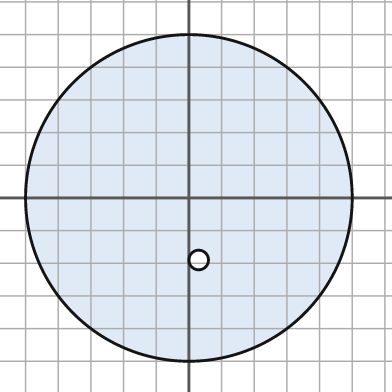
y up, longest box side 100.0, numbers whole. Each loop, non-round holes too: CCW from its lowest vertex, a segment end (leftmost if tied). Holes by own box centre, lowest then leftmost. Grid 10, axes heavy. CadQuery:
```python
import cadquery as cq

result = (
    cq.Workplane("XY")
    .moveTo(0.0, 0.0)
    .circle(50.0)
    .moveTo(3.0, -19.0)
    .circle(3.0)
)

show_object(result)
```